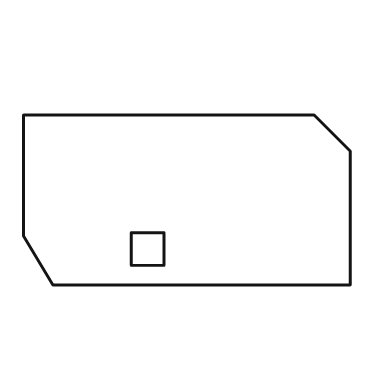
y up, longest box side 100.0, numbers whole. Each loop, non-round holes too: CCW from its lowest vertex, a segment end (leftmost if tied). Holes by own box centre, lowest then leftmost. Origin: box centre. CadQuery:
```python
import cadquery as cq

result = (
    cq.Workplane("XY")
    .moveTo(-41.0, -26.0)
    .lineTo(50.0, -26.0)
    .lineTo(50.0, 15.0)
    .lineTo(39.0, 26.0)
    .lineTo(-50.0, 26.0)
    .lineTo(-50.0, -11.0)
    .close()
    .moveTo(-17.0, -20.0)
    .lineTo(-7.0, -20.0)
    .lineTo(-7.0, -10.0)
    .lineTo(-17.0, -10.0)
    .close()
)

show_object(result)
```